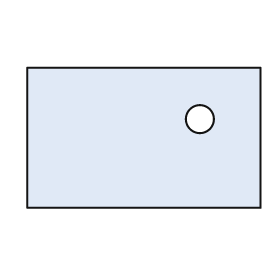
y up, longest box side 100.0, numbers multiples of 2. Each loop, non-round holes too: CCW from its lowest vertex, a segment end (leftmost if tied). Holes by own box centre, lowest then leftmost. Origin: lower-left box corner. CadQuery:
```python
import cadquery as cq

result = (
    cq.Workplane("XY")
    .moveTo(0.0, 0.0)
    .lineTo(100.0, 0.0)
    .lineTo(100.0, 60.0)
    .lineTo(0.0, 60.0)
    .close()
    .moveTo(74.0, 38.0)
    .circle(6.0)
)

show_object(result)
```